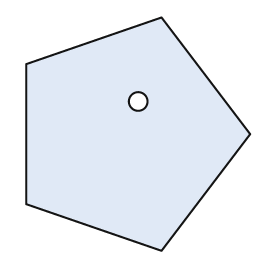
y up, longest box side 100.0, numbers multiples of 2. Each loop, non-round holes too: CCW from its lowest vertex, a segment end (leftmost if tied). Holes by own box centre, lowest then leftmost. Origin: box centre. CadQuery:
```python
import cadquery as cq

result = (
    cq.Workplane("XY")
    .moveTo(10.0, -50.0)
    .lineTo(48.0, 0.0)
    .lineTo(10.0, 50.0)
    .lineTo(-48.0, 30.0)
    .lineTo(-48.0, -30.0)
    .close()
    .moveTo(0.0, 14.0)
    .circle(4.0)
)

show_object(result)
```